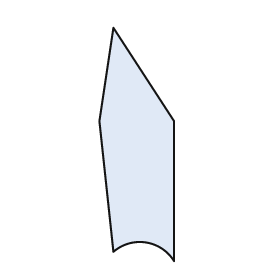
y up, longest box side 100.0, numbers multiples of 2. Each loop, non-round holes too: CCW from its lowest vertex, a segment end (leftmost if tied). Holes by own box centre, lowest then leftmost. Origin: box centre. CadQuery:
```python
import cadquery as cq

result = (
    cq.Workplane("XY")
    .moveTo(16.0, -50.0)
    .lineTo(16.0, 10.0)
    .lineTo(-10.0, 50.0)
    .lineTo(-16.0, 10.0)
    .lineTo(-10.0, -46.0)
    .threePointArc((4.0, -42.0), (16.0, -50.0))
    .close()
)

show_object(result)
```